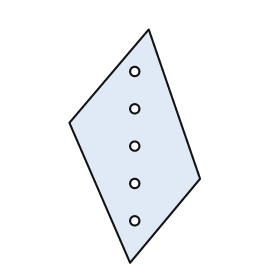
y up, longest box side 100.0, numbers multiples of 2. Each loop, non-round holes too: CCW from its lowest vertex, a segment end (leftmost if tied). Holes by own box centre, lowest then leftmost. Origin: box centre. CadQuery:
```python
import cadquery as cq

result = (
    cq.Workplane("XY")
    .moveTo(-2.0, -50.0)
    .lineTo(28.0, -14.0)
    .lineTo(6.0, 50.0)
    .lineTo(-28.0, 10.0)
    .close()
    .moveTo(0.0, -32.0)
    .circle(2.0)
    .moveTo(0.0, -16.0)
    .circle(2.0)
    .moveTo(0.0, 0.0)
    .circle(2.0)
    .moveTo(0.0, 16.0)
    .circle(2.0)
    .moveTo(0.0, 32.0)
    .circle(2.0)
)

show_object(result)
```